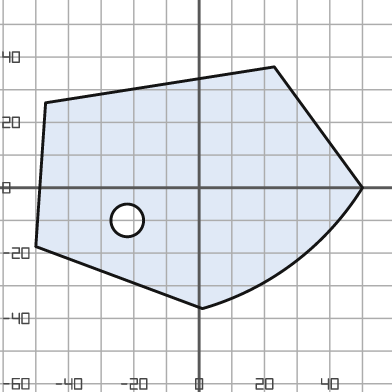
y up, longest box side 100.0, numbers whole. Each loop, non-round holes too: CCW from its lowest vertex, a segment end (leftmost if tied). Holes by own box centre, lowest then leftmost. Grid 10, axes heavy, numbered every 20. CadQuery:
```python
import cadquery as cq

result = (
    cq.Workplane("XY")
    .moveTo(1.0, -37.0)
    .threePointArc((29.0, -23.0), (50.0, 0.0))
    .lineTo(23.0, 37.0)
    .lineTo(-47.0, 26.0)
    .lineTo(-50.0, -18.0)
    .close()
    .moveTo(-22.0, -10.0)
    .circle(5.0)
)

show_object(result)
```